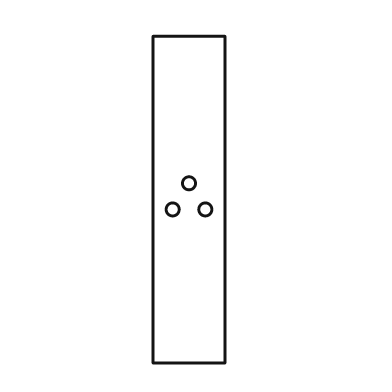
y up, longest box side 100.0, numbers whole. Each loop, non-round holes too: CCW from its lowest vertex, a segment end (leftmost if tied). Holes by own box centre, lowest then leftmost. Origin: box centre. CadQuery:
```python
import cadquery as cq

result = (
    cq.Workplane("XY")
    .moveTo(-11.0, -50.0)
    .lineTo(11.0, -50.0)
    .lineTo(11.0, 50.0)
    .lineTo(-11.0, 50.0)
    .close()
    .moveTo(-5.0, -3.0)
    .circle(2.0)
    .moveTo(5.0, -3.0)
    .circle(2.0)
    .moveTo(0.0, 5.0)
    .circle(2.0)
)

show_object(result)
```